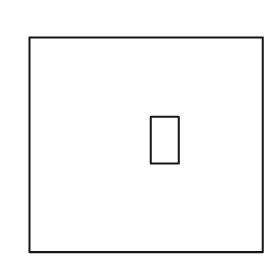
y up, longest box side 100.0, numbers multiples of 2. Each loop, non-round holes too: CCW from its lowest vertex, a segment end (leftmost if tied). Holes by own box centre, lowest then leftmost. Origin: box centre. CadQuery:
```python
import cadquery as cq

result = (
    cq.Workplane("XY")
    .moveTo(-50.0, -46.0)
    .lineTo(50.0, -46.0)
    .lineTo(50.0, 46.0)
    .lineTo(-50.0, 46.0)
    .close()
    .moveTo(2.0, -8.0)
    .lineTo(14.0, -8.0)
    .lineTo(14.0, 12.0)
    .lineTo(2.0, 12.0)
    .close()
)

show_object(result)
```